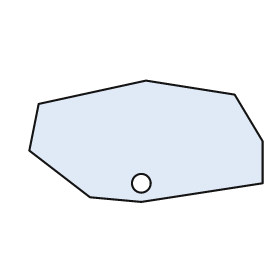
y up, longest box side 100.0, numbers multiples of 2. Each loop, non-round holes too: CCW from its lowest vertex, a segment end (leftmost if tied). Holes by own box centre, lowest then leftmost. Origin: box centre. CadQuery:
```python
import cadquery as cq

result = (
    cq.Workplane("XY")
    .moveTo(-2.0, -26.0)
    .lineTo(50.0, -18.0)
    .lineTo(50.0, 0.0)
    .lineTo(38.0, 20.0)
    .lineTo(0.0, 26.0)
    .lineTo(-46.0, 16.0)
    .lineTo(-50.0, -4.0)
    .lineTo(-24.0, -24.0)
    .close()
    .moveTo(-2.0, -18.0)
    .circle(4.0)
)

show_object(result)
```